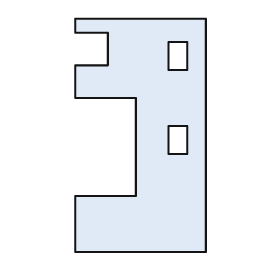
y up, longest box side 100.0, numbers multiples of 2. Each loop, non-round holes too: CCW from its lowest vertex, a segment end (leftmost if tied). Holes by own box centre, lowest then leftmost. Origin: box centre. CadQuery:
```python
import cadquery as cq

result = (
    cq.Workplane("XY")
    .moveTo(-28.0, -50.0)
    .lineTo(28.0, -50.0)
    .lineTo(28.0, 50.0)
    .lineTo(-28.0, 50.0)
    .lineTo(-28.0, 44.0)
    .lineTo(-14.0, 44.0)
    .lineTo(-14.0, 30.0)
    .lineTo(-28.0, 30.0)
    .lineTo(-28.0, 16.0)
    .lineTo(-2.0, 16.0)
    .lineTo(-2.0, -26.0)
    .lineTo(-28.0, -26.0)
    .close()
    .moveTo(12.0, -8.0)
    .lineTo(20.0, -8.0)
    .lineTo(20.0, 4.0)
    .lineTo(12.0, 4.0)
    .close()
    .moveTo(12.0, 28.0)
    .lineTo(20.0, 28.0)
    .lineTo(20.0, 40.0)
    .lineTo(12.0, 40.0)
    .close()
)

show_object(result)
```